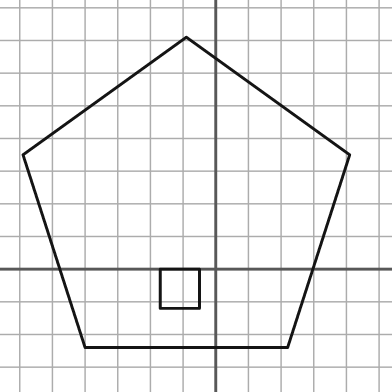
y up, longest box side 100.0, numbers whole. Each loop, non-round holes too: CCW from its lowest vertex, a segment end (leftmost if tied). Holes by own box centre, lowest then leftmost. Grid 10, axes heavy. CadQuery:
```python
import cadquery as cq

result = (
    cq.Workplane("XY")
    .moveTo(-40.0, -24.0)
    .lineTo(22.0, -24.0)
    .lineTo(41.0, 35.0)
    .lineTo(-9.0, 71.0)
    .lineTo(-59.0, 35.0)
    .close()
    .moveTo(-17.0, -12.0)
    .lineTo(-5.0, -12.0)
    .lineTo(-5.0, 0.0)
    .lineTo(-17.0, 0.0)
    .close()
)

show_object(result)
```